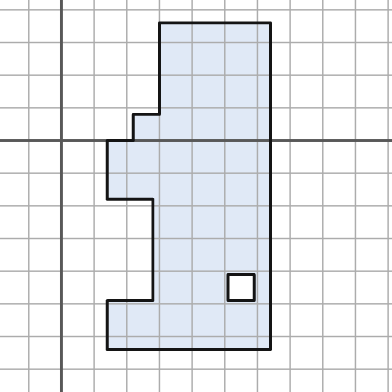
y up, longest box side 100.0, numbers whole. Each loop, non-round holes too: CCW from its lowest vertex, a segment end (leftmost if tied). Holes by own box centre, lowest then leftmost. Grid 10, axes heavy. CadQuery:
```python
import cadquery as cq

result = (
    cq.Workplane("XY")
    .moveTo(14.0, -64.0)
    .lineTo(64.0, -64.0)
    .lineTo(64.0, 36.0)
    .lineTo(30.0, 36.0)
    .lineTo(30.0, 8.0)
    .lineTo(22.0, 8.0)
    .lineTo(22.0, 0.0)
    .lineTo(14.0, 0.0)
    .lineTo(14.0, -18.0)
    .lineTo(28.0, -18.0)
    .lineTo(28.0, -49.0)
    .lineTo(14.0, -49.0)
    .close()
    .moveTo(51.0, -49.0)
    .lineTo(59.0, -49.0)
    .lineTo(59.0, -41.0)
    .lineTo(51.0, -41.0)
    .close()
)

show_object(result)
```